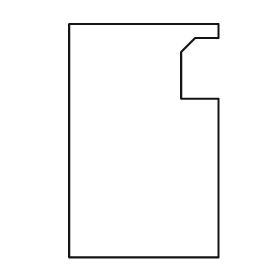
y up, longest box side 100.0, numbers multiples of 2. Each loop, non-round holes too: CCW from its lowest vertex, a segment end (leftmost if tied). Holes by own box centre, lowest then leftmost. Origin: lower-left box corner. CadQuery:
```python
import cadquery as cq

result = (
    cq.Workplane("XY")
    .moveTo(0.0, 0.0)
    .lineTo(64.0, 0.0)
    .lineTo(64.0, 68.0)
    .lineTo(48.0, 68.0)
    .lineTo(48.0, 88.0)
    .lineTo(54.0, 94.0)
    .lineTo(64.0, 94.0)
    .lineTo(64.0, 100.0)
    .lineTo(0.0, 100.0)
    .close()
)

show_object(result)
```